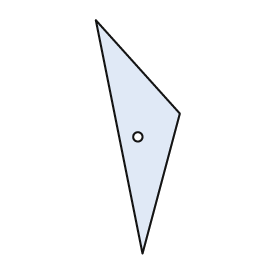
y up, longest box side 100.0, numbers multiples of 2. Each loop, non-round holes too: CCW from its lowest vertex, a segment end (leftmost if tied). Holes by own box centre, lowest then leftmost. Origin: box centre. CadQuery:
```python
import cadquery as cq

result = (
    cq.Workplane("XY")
    .moveTo(2.0, -50.0)
    .lineTo(18.0, 10.0)
    .lineTo(-18.0, 50.0)
    .close()
    .moveTo(0.0, 0.0)
    .circle(2.0)
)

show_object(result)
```